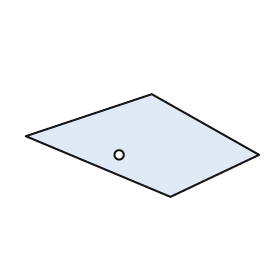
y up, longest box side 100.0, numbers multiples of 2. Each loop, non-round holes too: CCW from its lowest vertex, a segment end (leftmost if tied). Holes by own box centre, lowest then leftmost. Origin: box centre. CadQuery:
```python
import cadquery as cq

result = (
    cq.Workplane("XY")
    .moveTo(12.0, -22.0)
    .lineTo(50.0, -4.0)
    .lineTo(4.0, 22.0)
    .lineTo(-50.0, 4.0)
    .close()
    .moveTo(-10.0, -4.0)
    .circle(2.0)
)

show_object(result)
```